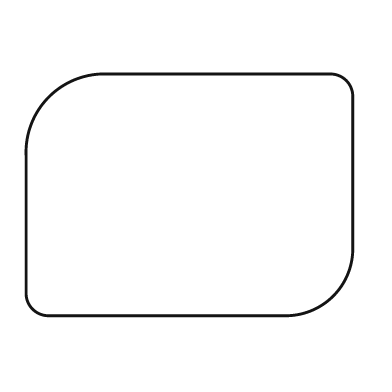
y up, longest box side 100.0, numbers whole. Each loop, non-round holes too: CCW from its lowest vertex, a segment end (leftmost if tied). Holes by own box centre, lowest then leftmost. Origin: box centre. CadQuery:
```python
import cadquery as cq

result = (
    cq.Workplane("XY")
    .moveTo(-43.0, -37.0)
    .lineTo(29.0, -37.0)
    .threePointArc((44.0, -31.0), (50.0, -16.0))
    .lineTo(50.0, 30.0)
    .threePointArc((48.0, 35.0), (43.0, 37.0))
    .lineTo(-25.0, 37.0)
    .threePointArc((-43.0, 30.0), (-50.0, 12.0))
    .lineTo(-50.0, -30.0)
    .threePointArc((-48.0, -35.0), (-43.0, -37.0))
    .close()
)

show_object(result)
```